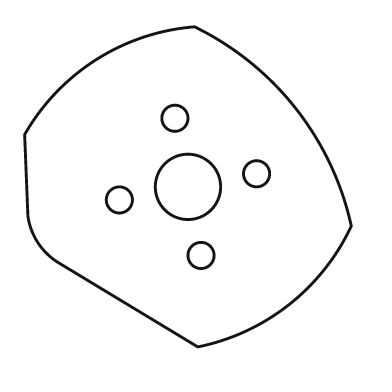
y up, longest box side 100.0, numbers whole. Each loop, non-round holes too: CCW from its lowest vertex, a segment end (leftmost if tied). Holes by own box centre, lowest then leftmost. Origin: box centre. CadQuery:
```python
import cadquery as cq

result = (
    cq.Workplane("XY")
    .moveTo(3.0, -49.0)
    .threePointArc((31.0, -36.0), (50.0, -12.0))
    .threePointArc((33.0, 24.0), (2.0, 49.0))
    .threePointArc((-28.0, 39.0), (-50.0, 16.0))
    .lineTo(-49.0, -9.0)
    .threePointArc((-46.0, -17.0), (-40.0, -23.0))
    .close()
    .moveTo(4.0, -21.0)
    .circle(4.0)
    .moveTo(-21.0, -4.0)
    .circle(4.0)
    .moveTo(0.0, 0.0)
    .circle(10.0)
    .moveTo(21.0, 4.0)
    .circle(4.0)
    .moveTo(-4.0, 21.0)
    .circle(4.0)
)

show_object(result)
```